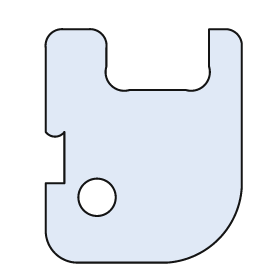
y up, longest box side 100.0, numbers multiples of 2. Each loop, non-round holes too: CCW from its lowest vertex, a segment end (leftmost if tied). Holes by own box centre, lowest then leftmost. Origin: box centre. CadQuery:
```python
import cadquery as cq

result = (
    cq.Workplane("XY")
    .moveTo(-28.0, -50.0)
    .lineTo(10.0, -50.0)
    .threePointArc((32.0, -40.0), (42.0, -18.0))
    .lineTo(42.0, 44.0)
    .threePointArc((40.0, 48.0), (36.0, 50.0))
    .lineTo(28.0, 50.0)
    .lineTo(28.0, 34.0)
    .threePointArc((26.0, 26.0), (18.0, 24.0))
    .lineTo(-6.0, 24.0)
    .threePointArc((-14.0, 26.0), (-16.0, 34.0))
    .lineTo(-16.0, 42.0)
    .threePointArc((-18.0, 48.0), (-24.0, 50.0))
    .lineTo(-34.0, 50.0)
    .threePointArc((-40.0, 48.0), (-42.0, 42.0))
    .lineTo(-42.0, 6.0)
    .threePointArc((-38.0, 4.0), (-34.0, 6.0))
    .lineTo(-34.0, -16.0)
    .lineTo(-42.0, -16.0)
    .lineTo(-42.0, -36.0)
    .threePointArc((-38.0, -46.0), (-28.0, -50.0))
    .close()
    .moveTo(-20.0, -22.0)
    .circle(8.0)
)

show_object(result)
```